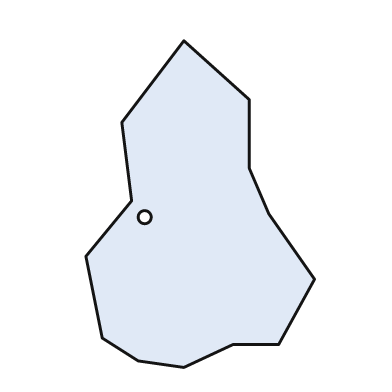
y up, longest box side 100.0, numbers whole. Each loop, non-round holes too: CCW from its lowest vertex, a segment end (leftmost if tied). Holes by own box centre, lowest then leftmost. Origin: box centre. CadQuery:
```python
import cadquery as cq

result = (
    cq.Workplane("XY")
    .moveTo(-5.0, -50.0)
    .lineTo(10.0, -43.0)
    .lineTo(24.0, -43.0)
    .lineTo(35.0, -23.0)
    .lineTo(21.0, -3.0)
    .lineTo(15.0, 11.0)
    .lineTo(15.0, 32.0)
    .lineTo(-5.0, 50.0)
    .lineTo(-24.0, 25.0)
    .lineTo(-21.0, 1.0)
    .lineTo(-35.0, -16.0)
    .lineTo(-30.0, -41.0)
    .lineTo(-19.0, -48.0)
    .close()
    .moveTo(-17.0, -4.0)
    .circle(2.0)
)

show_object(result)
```